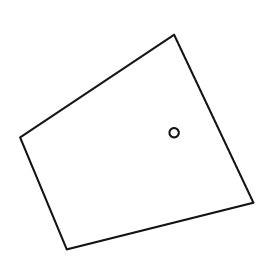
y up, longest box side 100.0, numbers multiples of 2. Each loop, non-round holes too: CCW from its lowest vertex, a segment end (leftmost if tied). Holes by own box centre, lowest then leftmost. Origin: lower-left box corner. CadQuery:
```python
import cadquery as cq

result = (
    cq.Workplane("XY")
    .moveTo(20.0, 0.0)
    .lineTo(100.0, 20.0)
    .lineTo(66.0, 92.0)
    .lineTo(0.0, 48.0)
    .close()
    .moveTo(66.0, 50.0)
    .circle(2.0)
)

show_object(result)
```